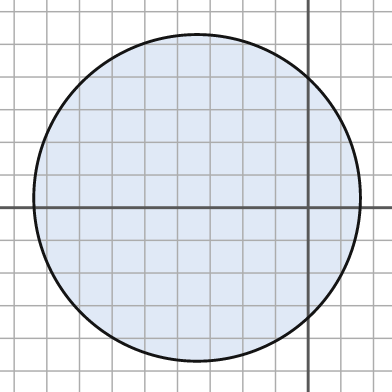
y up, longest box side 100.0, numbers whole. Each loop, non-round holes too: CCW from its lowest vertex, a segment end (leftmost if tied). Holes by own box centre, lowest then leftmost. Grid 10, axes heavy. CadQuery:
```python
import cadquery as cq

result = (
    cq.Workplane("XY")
    .moveTo(-34.0, 3.0)
    .circle(50.0)
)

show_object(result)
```